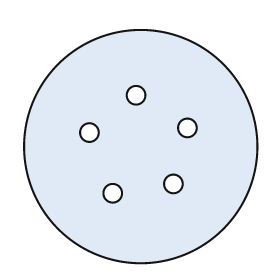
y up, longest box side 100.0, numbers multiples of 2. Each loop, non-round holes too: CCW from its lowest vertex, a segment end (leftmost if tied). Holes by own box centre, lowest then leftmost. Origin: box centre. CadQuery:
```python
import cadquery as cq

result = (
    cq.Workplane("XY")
    .moveTo(0.0, 0.0)
    .circle(50.0)
    .moveTo(-12.0, -20.0)
    .circle(4.0)
    .moveTo(14.0, -16.0)
    .circle(4.0)
    .moveTo(-22.0, 6.0)
    .circle(4.0)
    .moveTo(20.0, 8.0)
    .circle(4.0)
    .moveTo(-2.0, 22.0)
    .circle(4.0)
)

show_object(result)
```